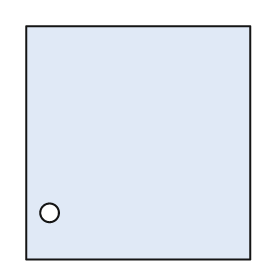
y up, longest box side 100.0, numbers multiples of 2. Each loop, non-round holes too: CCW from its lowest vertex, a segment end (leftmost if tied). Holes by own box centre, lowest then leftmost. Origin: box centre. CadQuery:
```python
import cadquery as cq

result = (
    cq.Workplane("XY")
    .moveTo(-48.0, -50.0)
    .lineTo(48.0, -50.0)
    .lineTo(48.0, 50.0)
    .lineTo(-48.0, 50.0)
    .close()
    .moveTo(-38.0, -30.0)
    .circle(4.0)
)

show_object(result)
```